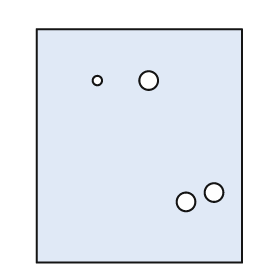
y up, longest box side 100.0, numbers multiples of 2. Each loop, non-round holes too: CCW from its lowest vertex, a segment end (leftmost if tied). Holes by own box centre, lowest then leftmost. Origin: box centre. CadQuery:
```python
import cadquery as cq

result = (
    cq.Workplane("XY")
    .moveTo(-44.0, -50.0)
    .lineTo(44.0, -50.0)
    .lineTo(44.0, 50.0)
    .lineTo(-44.0, 50.0)
    .close()
    .moveTo(20.0, -24.0)
    .circle(4.0)
    .moveTo(32.0, -20.0)
    .circle(4.0)
    .moveTo(-18.0, 28.0)
    .circle(2.0)
    .moveTo(4.0, 28.0)
    .circle(4.0)
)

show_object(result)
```